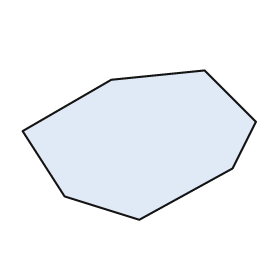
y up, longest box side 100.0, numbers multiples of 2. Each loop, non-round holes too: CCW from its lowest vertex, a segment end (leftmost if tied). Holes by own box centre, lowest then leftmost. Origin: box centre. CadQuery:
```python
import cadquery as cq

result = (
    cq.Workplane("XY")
    .moveTo(0.0, -32.0)
    .lineTo(40.0, -10.0)
    .lineTo(50.0, 10.0)
    .lineTo(28.0, 32.0)
    .lineTo(-12.0, 28.0)
    .lineTo(-50.0, 6.0)
    .lineTo(-32.0, -22.0)
    .close()
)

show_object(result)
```